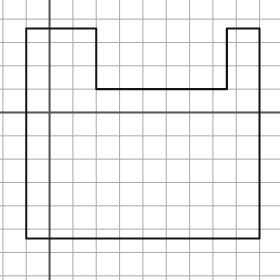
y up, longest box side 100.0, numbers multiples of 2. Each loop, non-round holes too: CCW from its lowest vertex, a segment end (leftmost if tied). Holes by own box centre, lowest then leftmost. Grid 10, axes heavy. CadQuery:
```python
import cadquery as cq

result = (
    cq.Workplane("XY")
    .moveTo(-10.0, -54.0)
    .lineTo(90.0, -54.0)
    .lineTo(90.0, 36.0)
    .lineTo(76.0, 36.0)
    .lineTo(76.0, 10.0)
    .lineTo(20.0, 10.0)
    .lineTo(20.0, 36.0)
    .lineTo(-10.0, 36.0)
    .close()
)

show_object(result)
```